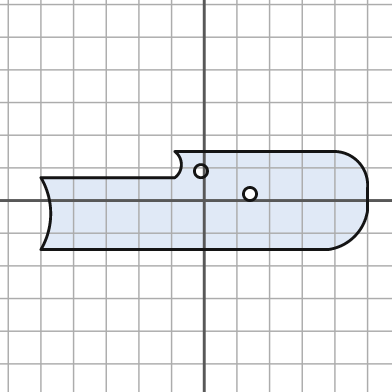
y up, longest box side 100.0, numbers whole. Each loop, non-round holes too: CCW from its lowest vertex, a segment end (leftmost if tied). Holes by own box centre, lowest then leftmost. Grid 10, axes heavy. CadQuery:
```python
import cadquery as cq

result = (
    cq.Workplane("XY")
    .moveTo(-50.0, -15.0)
    .lineTo(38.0, -15.0)
    .threePointArc((46.0, -11.0), (50.0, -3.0))
    .lineTo(50.0, 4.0)
    .threePointArc((47.0, 12.0), (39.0, 15.0))
    .lineTo(-9.0, 15.0)
    .threePointArc((-7.0, 11.0), (-9.0, 7.0))
    .lineTo(-50.0, 7.0)
    .threePointArc((-47.0, -4.0), (-50.0, -15.0))
    .close()
    .moveTo(14.0, 2.0)
    .circle(2.0)
    .moveTo(-1.0, 9.0)
    .circle(2.0)
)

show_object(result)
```